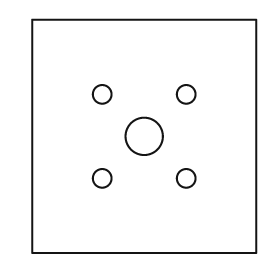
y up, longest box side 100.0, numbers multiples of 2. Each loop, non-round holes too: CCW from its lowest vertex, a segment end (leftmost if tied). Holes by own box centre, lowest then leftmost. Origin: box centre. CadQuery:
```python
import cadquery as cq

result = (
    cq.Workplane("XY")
    .moveTo(-48.0, -50.0)
    .lineTo(48.0, -50.0)
    .lineTo(48.0, 50.0)
    .lineTo(-48.0, 50.0)
    .close()
    .moveTo(-18.0, -18.0)
    .circle(4.0)
    .moveTo(18.0, -18.0)
    .circle(4.0)
    .moveTo(0.0, 0.0)
    .circle(8.0)
    .moveTo(-18.0, 18.0)
    .circle(4.0)
    .moveTo(18.0, 18.0)
    .circle(4.0)
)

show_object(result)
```